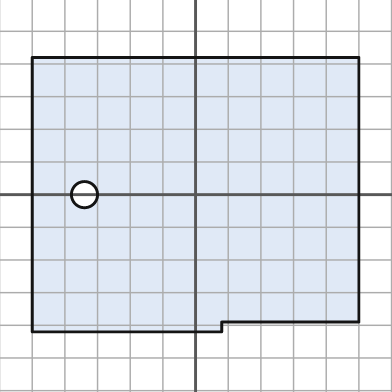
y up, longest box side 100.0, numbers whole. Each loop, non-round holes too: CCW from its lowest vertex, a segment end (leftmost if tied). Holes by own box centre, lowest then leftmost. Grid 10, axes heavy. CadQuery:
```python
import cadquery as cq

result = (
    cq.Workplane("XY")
    .moveTo(-50.0, -42.0)
    .lineTo(8.0, -42.0)
    .lineTo(8.0, -39.0)
    .lineTo(50.0, -39.0)
    .lineTo(50.0, 42.0)
    .lineTo(-50.0, 42.0)
    .close()
    .moveTo(-34.0, 0.0)
    .circle(4.0)
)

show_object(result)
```